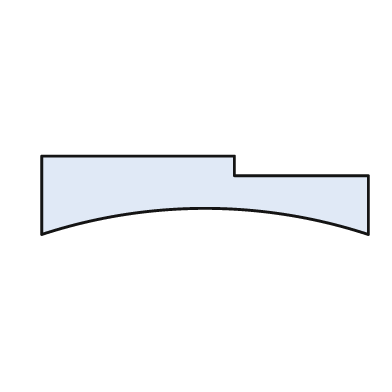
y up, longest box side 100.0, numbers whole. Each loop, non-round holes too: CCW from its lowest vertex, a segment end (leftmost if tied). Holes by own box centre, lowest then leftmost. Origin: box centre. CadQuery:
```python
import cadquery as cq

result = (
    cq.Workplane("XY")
    .moveTo(-50.0, -12.0)
    .threePointArc((0.0, -4.0), (50.0, -12.0))
    .lineTo(50.0, 6.0)
    .lineTo(9.0, 6.0)
    .lineTo(9.0, 12.0)
    .lineTo(-50.0, 12.0)
    .close()
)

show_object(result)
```